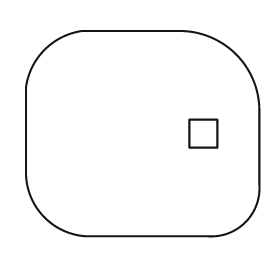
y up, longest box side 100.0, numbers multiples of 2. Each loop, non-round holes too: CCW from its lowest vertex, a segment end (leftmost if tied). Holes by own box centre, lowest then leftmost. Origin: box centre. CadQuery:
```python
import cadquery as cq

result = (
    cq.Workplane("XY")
    .moveTo(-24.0, -44.0)
    .lineTo(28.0, -44.0)
    .threePointArc((44.0, -38.0), (50.0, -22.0))
    .lineTo(50.0, 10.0)
    .threePointArc((40.0, 34.0), (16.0, 44.0))
    .lineTo(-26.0, 44.0)
    .threePointArc((-42.0, 36.0), (-50.0, 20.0))
    .lineTo(-50.0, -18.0)
    .threePointArc((-42.0, -36.0), (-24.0, -44.0))
    .close()
    .moveTo(20.0, -6.0)
    .lineTo(32.0, -6.0)
    .lineTo(32.0, 6.0)
    .lineTo(20.0, 6.0)
    .close()
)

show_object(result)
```